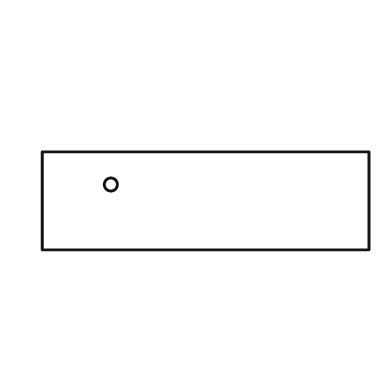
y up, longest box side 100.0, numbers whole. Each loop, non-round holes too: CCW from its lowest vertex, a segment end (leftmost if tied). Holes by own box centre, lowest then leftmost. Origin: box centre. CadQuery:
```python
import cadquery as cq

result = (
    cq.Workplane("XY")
    .moveTo(-50.0, -15.0)
    .lineTo(50.0, -15.0)
    .lineTo(50.0, 15.0)
    .lineTo(-50.0, 15.0)
    .close()
    .moveTo(-29.0, 5.0)
    .circle(2.0)
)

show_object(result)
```